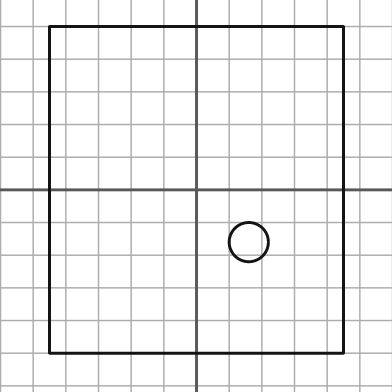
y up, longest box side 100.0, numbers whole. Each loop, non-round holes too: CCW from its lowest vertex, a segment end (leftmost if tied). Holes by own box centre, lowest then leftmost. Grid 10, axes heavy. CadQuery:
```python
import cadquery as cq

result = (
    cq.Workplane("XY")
    .moveTo(-45.0, -50.0)
    .lineTo(45.0, -50.0)
    .lineTo(45.0, 50.0)
    .lineTo(-45.0, 50.0)
    .close()
    .moveTo(16.0, -16.0)
    .circle(6.0)
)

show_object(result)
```